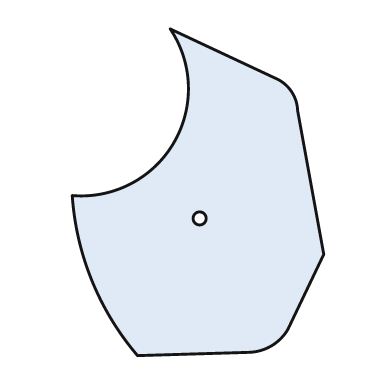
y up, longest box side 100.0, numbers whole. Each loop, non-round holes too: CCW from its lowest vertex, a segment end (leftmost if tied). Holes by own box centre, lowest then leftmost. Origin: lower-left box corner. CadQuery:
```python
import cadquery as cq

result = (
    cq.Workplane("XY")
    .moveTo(20.0, 0.0)
    .lineTo(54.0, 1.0)
    .threePointArc((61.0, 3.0), (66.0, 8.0))
    .lineTo(77.0, 31.0)
    .lineTo(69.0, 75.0)
    .threePointArc((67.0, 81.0), (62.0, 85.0))
    .lineTo(30.0, 100.0)
    .threePointArc((31.0, 65.0), (0.0, 49.0))
    .threePointArc((6.0, 23.0), (20.0, 0.0))
    .close()
    .moveTo(39.0, 42.0)
    .circle(2.0)
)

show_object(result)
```